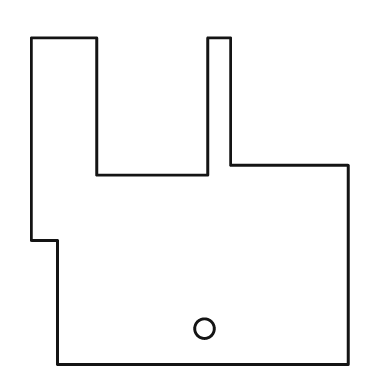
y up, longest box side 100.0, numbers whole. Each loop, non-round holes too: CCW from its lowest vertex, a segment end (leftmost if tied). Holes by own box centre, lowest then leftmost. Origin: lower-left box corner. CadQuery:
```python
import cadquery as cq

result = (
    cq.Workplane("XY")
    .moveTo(8.0, 0.0)
    .lineTo(97.0, 0.0)
    .lineTo(97.0, 61.0)
    .lineTo(61.0, 61.0)
    .lineTo(61.0, 100.0)
    .lineTo(54.0, 100.0)
    .lineTo(54.0, 58.0)
    .lineTo(20.0, 58.0)
    .lineTo(20.0, 100.0)
    .lineTo(0.0, 100.0)
    .lineTo(0.0, 38.0)
    .lineTo(8.0, 38.0)
    .close()
    .moveTo(53.0, 11.0)
    .circle(3.0)
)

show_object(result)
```